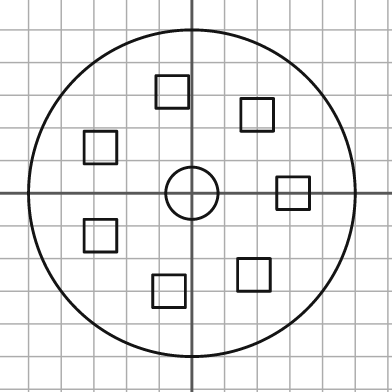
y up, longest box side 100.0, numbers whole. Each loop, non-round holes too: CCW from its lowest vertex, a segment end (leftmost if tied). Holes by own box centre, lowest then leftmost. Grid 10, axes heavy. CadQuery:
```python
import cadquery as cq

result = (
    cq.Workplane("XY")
    .moveTo(0.0, 0.0)
    .circle(50.0)
    .moveTo(-12.0, -35.0)
    .lineTo(-2.0, -35.0)
    .lineTo(-2.0, -25.0)
    .lineTo(-12.0, -25.0)
    .close()
    .moveTo(14.0, -30.0)
    .lineTo(24.0, -30.0)
    .lineTo(24.0, -20.0)
    .lineTo(14.0, -20.0)
    .close()
    .moveTo(-33.0, -18.0)
    .lineTo(-23.0, -18.0)
    .lineTo(-23.0, -8.0)
    .lineTo(-33.0, -8.0)
    .close()
    .moveTo(0.0, 0.0)
    .circle(8.0)
    .moveTo(26.0, -5.0)
    .lineTo(36.0, -5.0)
    .lineTo(36.0, 5.0)
    .lineTo(26.0, 5.0)
    .close()
    .moveTo(-33.0, 9.0)
    .lineTo(-23.0, 9.0)
    .lineTo(-23.0, 19.0)
    .lineTo(-33.0, 19.0)
    .close()
    .moveTo(15.0, 19.0)
    .lineTo(25.0, 19.0)
    .lineTo(25.0, 29.0)
    .lineTo(15.0, 29.0)
    .close()
    .moveTo(-11.0, 26.0)
    .lineTo(-1.0, 26.0)
    .lineTo(-1.0, 36.0)
    .lineTo(-11.0, 36.0)
    .close()
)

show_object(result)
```